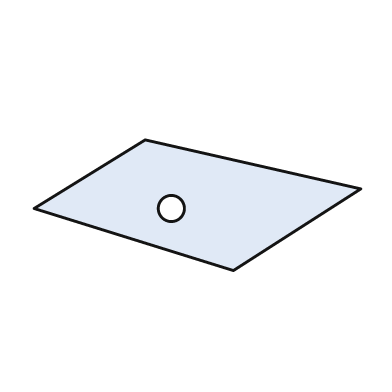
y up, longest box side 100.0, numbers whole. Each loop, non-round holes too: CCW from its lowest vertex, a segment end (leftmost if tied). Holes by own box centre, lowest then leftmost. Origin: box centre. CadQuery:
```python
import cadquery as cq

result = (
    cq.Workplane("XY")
    .moveTo(11.0, -20.0)
    .lineTo(50.0, 5.0)
    .lineTo(-16.0, 20.0)
    .lineTo(-50.0, -1.0)
    .close()
    .moveTo(-8.0, -1.0)
    .circle(4.0)
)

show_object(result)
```